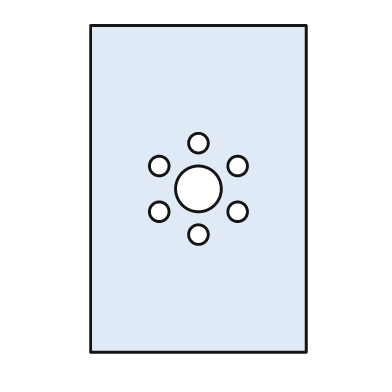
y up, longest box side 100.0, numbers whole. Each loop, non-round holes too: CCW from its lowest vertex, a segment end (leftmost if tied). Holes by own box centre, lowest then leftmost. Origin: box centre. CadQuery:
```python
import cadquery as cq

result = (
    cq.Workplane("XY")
    .moveTo(-33.0, -50.0)
    .lineTo(33.0, -50.0)
    .lineTo(33.0, 50.0)
    .lineTo(-33.0, 50.0)
    .close()
    .moveTo(0.0, -14.0)
    .circle(3.0)
    .moveTo(-12.0, -7.0)
    .circle(3.0)
    .moveTo(12.0, -7.0)
    .circle(3.0)
    .moveTo(0.0, 0.0)
    .circle(7.0)
    .moveTo(-12.0, 7.0)
    .circle(3.0)
    .moveTo(12.0, 7.0)
    .circle(3.0)
    .moveTo(0.0, 14.0)
    .circle(3.0)
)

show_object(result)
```